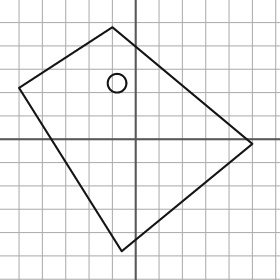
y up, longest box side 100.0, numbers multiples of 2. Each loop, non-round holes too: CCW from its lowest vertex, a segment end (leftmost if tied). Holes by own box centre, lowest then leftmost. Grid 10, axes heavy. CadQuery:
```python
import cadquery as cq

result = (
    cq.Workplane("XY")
    .moveTo(-6.0, -48.0)
    .lineTo(50.0, -2.0)
    .lineTo(-10.0, 48.0)
    .lineTo(-50.0, 22.0)
    .close()
    .moveTo(-8.0, 24.0)
    .circle(4.0)
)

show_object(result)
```